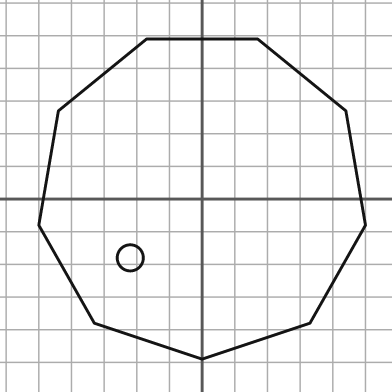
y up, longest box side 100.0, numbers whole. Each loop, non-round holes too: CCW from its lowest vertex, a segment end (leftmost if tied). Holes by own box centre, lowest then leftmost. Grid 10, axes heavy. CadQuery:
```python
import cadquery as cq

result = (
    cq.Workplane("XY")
    .moveTo(0.0, -49.0)
    .lineTo(33.0, -38.0)
    .lineTo(50.0, -8.0)
    .lineTo(44.0, 27.0)
    .lineTo(17.0, 49.0)
    .lineTo(-17.0, 49.0)
    .lineTo(-44.0, 27.0)
    .lineTo(-50.0, -8.0)
    .lineTo(-33.0, -38.0)
    .close()
    .moveTo(-22.0, -18.0)
    .circle(4.0)
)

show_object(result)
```